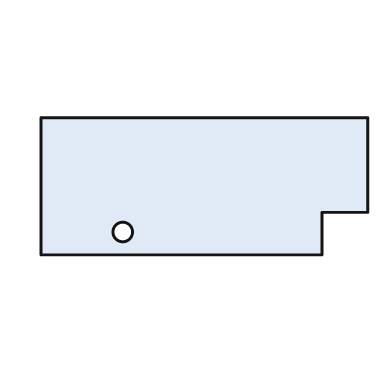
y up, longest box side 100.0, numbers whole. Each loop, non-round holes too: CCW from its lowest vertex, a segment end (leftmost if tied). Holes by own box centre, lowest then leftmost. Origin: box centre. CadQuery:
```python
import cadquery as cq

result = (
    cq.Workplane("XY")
    .moveTo(-50.0, -21.0)
    .lineTo(36.0, -21.0)
    .lineTo(36.0, -8.0)
    .lineTo(50.0, -8.0)
    .lineTo(50.0, 21.0)
    .lineTo(-50.0, 21.0)
    .close()
    .moveTo(-25.0, -14.0)
    .circle(3.0)
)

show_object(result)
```